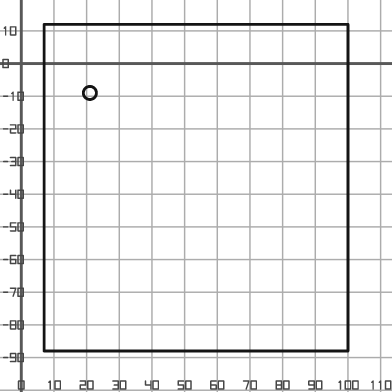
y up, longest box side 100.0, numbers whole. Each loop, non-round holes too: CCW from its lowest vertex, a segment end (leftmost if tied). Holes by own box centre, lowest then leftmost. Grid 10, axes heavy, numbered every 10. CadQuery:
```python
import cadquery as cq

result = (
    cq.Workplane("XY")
    .moveTo(7.0, -88.0)
    .lineTo(100.0, -88.0)
    .lineTo(100.0, 12.0)
    .lineTo(7.0, 12.0)
    .close()
    .moveTo(21.0, -9.0)
    .circle(2.0)
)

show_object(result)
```